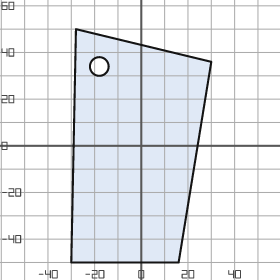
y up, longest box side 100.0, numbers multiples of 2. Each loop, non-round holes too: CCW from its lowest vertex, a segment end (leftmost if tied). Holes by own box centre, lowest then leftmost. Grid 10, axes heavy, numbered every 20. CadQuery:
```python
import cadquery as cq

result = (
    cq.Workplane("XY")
    .moveTo(-30.0, -50.0)
    .lineTo(16.0, -50.0)
    .lineTo(30.0, 36.0)
    .lineTo(-28.0, 50.0)
    .close()
    .moveTo(-18.0, 34.0)
    .circle(4.0)
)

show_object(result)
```